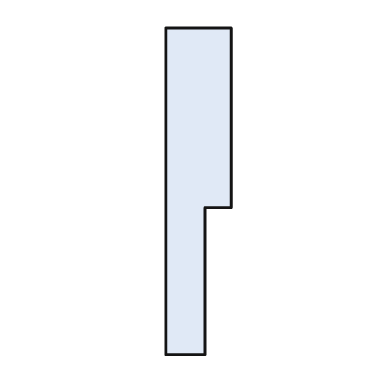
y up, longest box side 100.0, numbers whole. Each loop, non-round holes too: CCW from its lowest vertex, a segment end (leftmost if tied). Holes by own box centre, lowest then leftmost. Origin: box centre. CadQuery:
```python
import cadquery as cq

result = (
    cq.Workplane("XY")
    .moveTo(-10.0, -50.0)
    .lineTo(2.0, -50.0)
    .lineTo(2.0, -5.0)
    .lineTo(10.0, -5.0)
    .lineTo(10.0, 50.0)
    .lineTo(-10.0, 50.0)
    .close()
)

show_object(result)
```